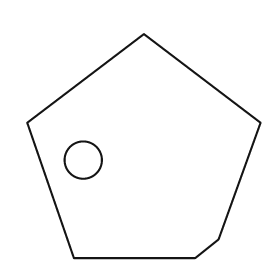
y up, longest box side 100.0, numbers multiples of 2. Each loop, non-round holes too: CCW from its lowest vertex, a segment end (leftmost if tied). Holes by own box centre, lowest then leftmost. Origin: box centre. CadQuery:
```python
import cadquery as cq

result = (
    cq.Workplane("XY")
    .moveTo(-30.0, -48.0)
    .lineTo(22.0, -48.0)
    .lineTo(32.0, -40.0)
    .lineTo(50.0, 10.0)
    .lineTo(0.0, 48.0)
    .lineTo(-50.0, 10.0)
    .close()
    .moveTo(-26.0, -6.0)
    .circle(8.0)
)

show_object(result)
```